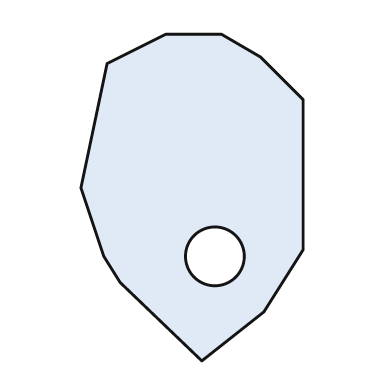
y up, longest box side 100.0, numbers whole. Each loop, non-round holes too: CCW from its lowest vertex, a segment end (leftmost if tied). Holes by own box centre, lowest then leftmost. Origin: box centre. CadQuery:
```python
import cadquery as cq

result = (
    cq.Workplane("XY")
    .moveTo(3.0, -50.0)
    .lineTo(22.0, -35.0)
    .lineTo(34.0, -16.0)
    .lineTo(34.0, 30.0)
    .lineTo(21.0, 43.0)
    .lineTo(9.0, 50.0)
    .lineTo(-8.0, 50.0)
    .lineTo(-26.0, 41.0)
    .lineTo(-34.0, 3.0)
    .lineTo(-27.0, -18.0)
    .lineTo(-22.0, -26.0)
    .close()
    .moveTo(7.0, -18.0)
    .circle(9.0)
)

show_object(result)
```